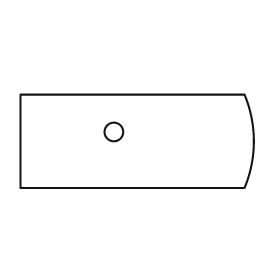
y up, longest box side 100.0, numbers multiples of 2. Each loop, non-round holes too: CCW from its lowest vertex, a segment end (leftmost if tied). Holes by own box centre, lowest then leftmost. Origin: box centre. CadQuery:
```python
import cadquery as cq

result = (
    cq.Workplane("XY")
    .moveTo(-50.0, -20.0)
    .lineTo(46.0, -20.0)
    .threePointArc((50.0, 0.0), (46.0, 20.0))
    .lineTo(-50.0, 20.0)
    .close()
    .moveTo(-10.0, 4.0)
    .circle(4.0)
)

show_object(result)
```